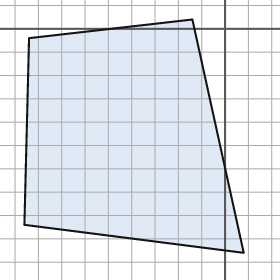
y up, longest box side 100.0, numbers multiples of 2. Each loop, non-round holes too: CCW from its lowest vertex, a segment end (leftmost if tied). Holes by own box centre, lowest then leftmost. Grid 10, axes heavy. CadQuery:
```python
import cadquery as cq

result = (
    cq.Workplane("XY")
    .moveTo(8.0, -96.0)
    .lineTo(-14.0, 4.0)
    .lineTo(-84.0, -4.0)
    .lineTo(-86.0, -84.0)
    .close()
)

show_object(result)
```